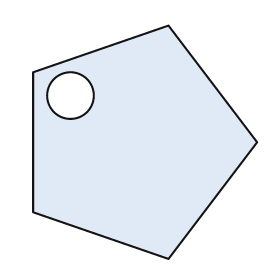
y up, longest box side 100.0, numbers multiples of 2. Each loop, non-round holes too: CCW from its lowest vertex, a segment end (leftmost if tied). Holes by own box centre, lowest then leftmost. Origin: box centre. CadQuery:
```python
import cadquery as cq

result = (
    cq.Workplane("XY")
    .moveTo(10.0, -50.0)
    .lineTo(48.0, 0.0)
    .lineTo(10.0, 50.0)
    .lineTo(-48.0, 30.0)
    .lineTo(-48.0, -30.0)
    .close()
    .moveTo(-32.0, 20.0)
    .circle(10.0)
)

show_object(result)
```